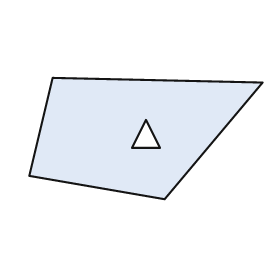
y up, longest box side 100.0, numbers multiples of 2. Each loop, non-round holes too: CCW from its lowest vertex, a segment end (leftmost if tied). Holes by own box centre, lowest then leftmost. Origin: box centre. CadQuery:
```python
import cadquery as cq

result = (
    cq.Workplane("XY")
    .moveTo(8.0, -26.0)
    .lineTo(50.0, 24.0)
    .lineTo(-40.0, 26.0)
    .lineTo(-50.0, -16.0)
    .close()
    .moveTo(-6.0, -4.0)
    .lineTo(6.0, -4.0)
    .lineTo(0.0, 8.0)
    .close()
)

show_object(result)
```